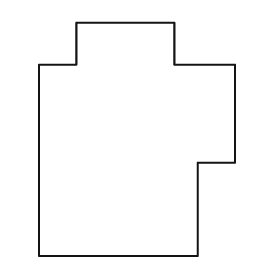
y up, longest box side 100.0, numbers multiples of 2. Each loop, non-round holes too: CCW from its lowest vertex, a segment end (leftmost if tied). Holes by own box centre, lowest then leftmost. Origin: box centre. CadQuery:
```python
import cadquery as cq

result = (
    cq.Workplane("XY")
    .moveTo(-42.0, -50.0)
    .lineTo(26.0, -50.0)
    .lineTo(26.0, -10.0)
    .lineTo(42.0, -10.0)
    .lineTo(42.0, 32.0)
    .lineTo(16.0, 32.0)
    .lineTo(16.0, 50.0)
    .lineTo(-26.0, 50.0)
    .lineTo(-26.0, 32.0)
    .lineTo(-42.0, 32.0)
    .close()
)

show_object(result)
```